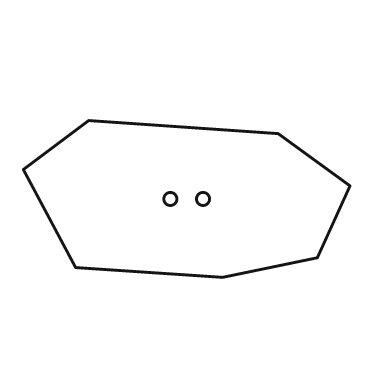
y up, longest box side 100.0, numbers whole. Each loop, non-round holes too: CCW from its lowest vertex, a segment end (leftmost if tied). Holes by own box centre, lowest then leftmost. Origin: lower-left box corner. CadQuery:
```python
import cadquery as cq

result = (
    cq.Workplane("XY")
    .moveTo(61.0, 0.0)
    .lineTo(90.0, 6.0)
    .lineTo(100.0, 28.0)
    .lineTo(78.0, 44.0)
    .lineTo(20.0, 48.0)
    .lineTo(0.0, 33.0)
    .lineTo(16.0, 3.0)
    .close()
    .moveTo(45.0, 24.0)
    .circle(2.0)
    .moveTo(55.0, 24.0)
    .circle(2.0)
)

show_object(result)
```